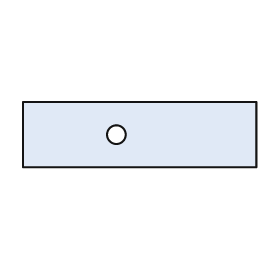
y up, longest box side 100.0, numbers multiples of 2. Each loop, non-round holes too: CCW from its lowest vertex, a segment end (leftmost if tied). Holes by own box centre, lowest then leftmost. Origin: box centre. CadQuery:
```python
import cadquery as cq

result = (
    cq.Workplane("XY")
    .moveTo(-50.0, -14.0)
    .lineTo(50.0, -14.0)
    .lineTo(50.0, 14.0)
    .lineTo(-50.0, 14.0)
    .close()
    .moveTo(-10.0, 0.0)
    .circle(4.0)
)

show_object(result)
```